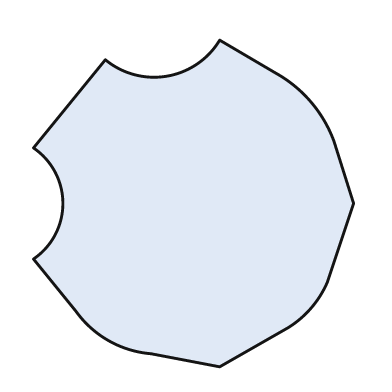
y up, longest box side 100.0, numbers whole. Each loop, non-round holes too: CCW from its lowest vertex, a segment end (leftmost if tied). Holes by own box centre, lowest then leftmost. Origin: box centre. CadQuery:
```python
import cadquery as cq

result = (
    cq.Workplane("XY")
    .moveTo(8.0, -50.0)
    .lineTo(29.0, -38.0)
    .threePointArc((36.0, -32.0), (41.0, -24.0))
    .lineTo(49.0, 0.0)
    .lineTo(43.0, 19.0)
    .threePointArc((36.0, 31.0), (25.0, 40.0))
    .lineTo(8.0, 50.0)
    .threePointArc((-8.0, 39.0), (-27.0, 44.0))
    .lineTo(-49.0, 17.0)
    .threePointArc((-40.0, 0.0), (-49.0, -17.0))
    .lineTo(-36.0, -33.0)
    .threePointArc((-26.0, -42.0), (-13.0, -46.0))
    .close()
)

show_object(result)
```